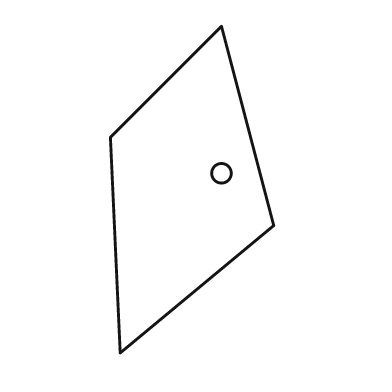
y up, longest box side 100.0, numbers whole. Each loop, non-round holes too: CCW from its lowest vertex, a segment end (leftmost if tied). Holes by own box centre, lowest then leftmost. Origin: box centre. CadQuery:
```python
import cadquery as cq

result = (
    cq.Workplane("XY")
    .moveTo(-22.0, -50.0)
    .lineTo(25.0, -11.0)
    .lineTo(9.0, 50.0)
    .lineTo(-25.0, 16.0)
    .close()
    .moveTo(9.0, 5.0)
    .circle(3.0)
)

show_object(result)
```